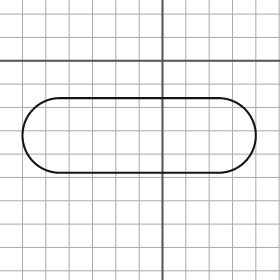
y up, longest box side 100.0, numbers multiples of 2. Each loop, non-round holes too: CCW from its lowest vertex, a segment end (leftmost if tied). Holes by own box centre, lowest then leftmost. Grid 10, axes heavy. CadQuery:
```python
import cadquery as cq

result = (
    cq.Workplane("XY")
    .moveTo(-44.0, -48.0)
    .lineTo(24.0, -48.0)
    .threePointArc((40.0, -32.0), (24.0, -16.0))
    .lineTo(-44.0, -16.0)
    .threePointArc((-60.0, -32.0), (-44.0, -48.0))
    .close()
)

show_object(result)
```